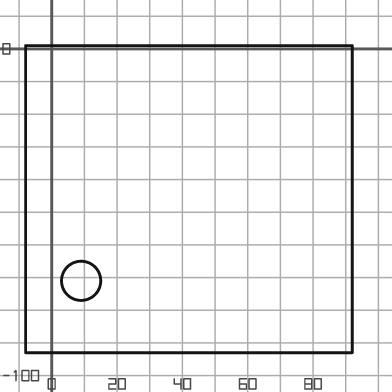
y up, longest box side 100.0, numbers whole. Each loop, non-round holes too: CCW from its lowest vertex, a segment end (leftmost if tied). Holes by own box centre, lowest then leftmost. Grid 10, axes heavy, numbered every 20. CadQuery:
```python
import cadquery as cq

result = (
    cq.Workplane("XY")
    .moveTo(-8.0, -93.0)
    .lineTo(92.0, -93.0)
    .lineTo(92.0, 1.0)
    .lineTo(-8.0, 1.0)
    .close()
    .moveTo(9.0, -71.0)
    .circle(6.0)
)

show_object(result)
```